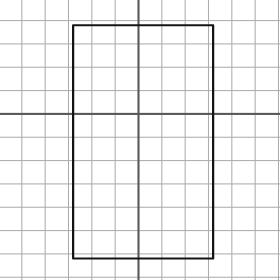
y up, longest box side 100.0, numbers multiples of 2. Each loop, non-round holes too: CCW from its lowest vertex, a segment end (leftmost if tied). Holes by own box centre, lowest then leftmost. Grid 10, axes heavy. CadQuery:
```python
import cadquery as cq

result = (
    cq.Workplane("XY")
    .moveTo(-28.0, -62.0)
    .lineTo(32.0, -62.0)
    .lineTo(32.0, 38.0)
    .lineTo(-28.0, 38.0)
    .close()
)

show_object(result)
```